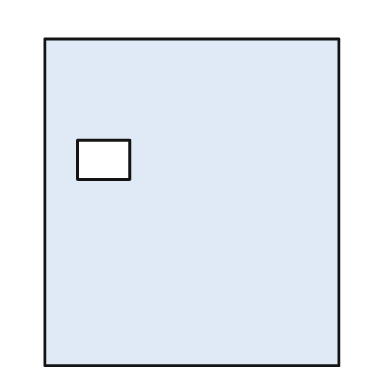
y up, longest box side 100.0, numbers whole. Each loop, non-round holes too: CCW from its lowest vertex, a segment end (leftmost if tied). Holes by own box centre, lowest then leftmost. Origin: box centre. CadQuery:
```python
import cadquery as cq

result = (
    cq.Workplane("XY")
    .moveTo(-45.0, -50.0)
    .lineTo(45.0, -50.0)
    .lineTo(45.0, 50.0)
    .lineTo(-45.0, 50.0)
    .close()
    .moveTo(-35.0, 7.0)
    .lineTo(-19.0, 7.0)
    .lineTo(-19.0, 19.0)
    .lineTo(-35.0, 19.0)
    .close()
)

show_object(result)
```